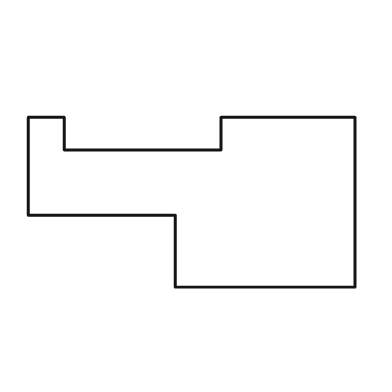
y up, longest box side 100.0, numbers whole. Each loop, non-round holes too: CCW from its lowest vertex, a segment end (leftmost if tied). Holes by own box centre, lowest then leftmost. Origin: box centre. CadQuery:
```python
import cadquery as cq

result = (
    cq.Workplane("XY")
    .moveTo(-5.0, -26.0)
    .lineTo(50.0, -26.0)
    .lineTo(50.0, 26.0)
    .lineTo(9.0, 26.0)
    .lineTo(9.0, 16.0)
    .lineTo(-39.0, 16.0)
    .lineTo(-39.0, 26.0)
    .lineTo(-50.0, 26.0)
    .lineTo(-50.0, -4.0)
    .lineTo(-5.0, -4.0)
    .close()
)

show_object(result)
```